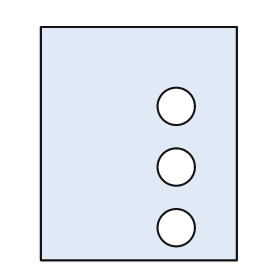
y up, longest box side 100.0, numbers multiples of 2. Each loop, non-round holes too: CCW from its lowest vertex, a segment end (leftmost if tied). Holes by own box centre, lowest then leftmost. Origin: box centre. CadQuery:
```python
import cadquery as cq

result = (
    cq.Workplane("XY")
    .moveTo(-42.0, -50.0)
    .lineTo(42.0, -50.0)
    .lineTo(42.0, 50.0)
    .lineTo(-42.0, 50.0)
    .close()
    .moveTo(16.0, -36.0)
    .circle(8.0)
    .moveTo(16.0, -10.0)
    .circle(8.0)
    .moveTo(16.0, 16.0)
    .circle(8.0)
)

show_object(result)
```